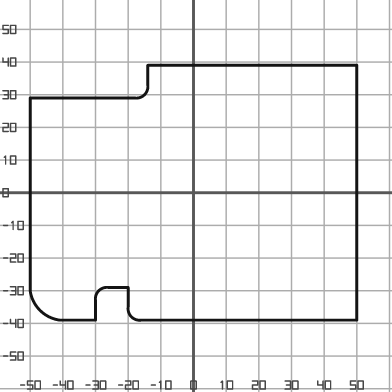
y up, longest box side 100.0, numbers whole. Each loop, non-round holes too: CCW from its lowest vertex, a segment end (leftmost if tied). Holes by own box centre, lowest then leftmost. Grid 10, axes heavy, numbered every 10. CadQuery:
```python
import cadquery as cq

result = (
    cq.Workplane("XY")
    .moveTo(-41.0, -39.0)
    .lineTo(-30.0, -39.0)
    .lineTo(-30.0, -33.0)
    .threePointArc((-29.0, -30.0), (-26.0, -29.0))
    .lineTo(-20.0, -29.0)
    .lineTo(-20.0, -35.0)
    .threePointArc((-19.0, -38.0), (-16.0, -39.0))
    .lineTo(50.0, -39.0)
    .lineTo(50.0, 39.0)
    .lineTo(-14.0, 39.0)
    .lineTo(-14.0, 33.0)
    .threePointArc((-15.0, 30.0), (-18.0, 29.0))
    .lineTo(-50.0, 29.0)
    .lineTo(-50.0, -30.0)
    .threePointArc((-47.0, -36.0), (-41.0, -39.0))
    .close()
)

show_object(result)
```